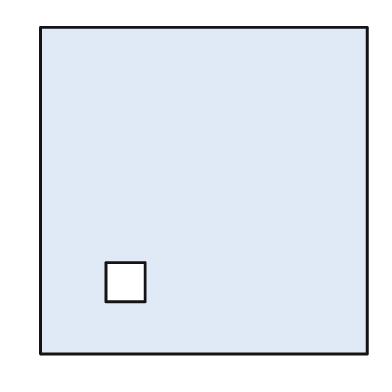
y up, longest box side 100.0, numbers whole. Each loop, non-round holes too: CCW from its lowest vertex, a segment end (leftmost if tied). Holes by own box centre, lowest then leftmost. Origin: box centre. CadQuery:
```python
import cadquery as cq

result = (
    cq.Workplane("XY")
    .moveTo(-50.0, -50.0)
    .lineTo(50.0, -50.0)
    .lineTo(50.0, 50.0)
    .lineTo(-50.0, 50.0)
    .close()
    .moveTo(-30.0, -34.0)
    .lineTo(-18.0, -34.0)
    .lineTo(-18.0, -22.0)
    .lineTo(-30.0, -22.0)
    .close()
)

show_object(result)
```